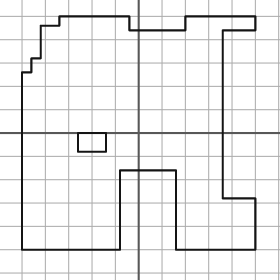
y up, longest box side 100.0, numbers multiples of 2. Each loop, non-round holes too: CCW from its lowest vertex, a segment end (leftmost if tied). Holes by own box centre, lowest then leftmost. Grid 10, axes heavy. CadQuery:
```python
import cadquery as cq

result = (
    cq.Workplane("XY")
    .moveTo(-50.0, -50.0)
    .lineTo(-8.0, -50.0)
    .lineTo(-8.0, -16.0)
    .lineTo(16.0, -16.0)
    .lineTo(16.0, -50.0)
    .lineTo(50.0, -50.0)
    .lineTo(50.0, -28.0)
    .lineTo(36.0, -28.0)
    .lineTo(36.0, 44.0)
    .lineTo(50.0, 44.0)
    .lineTo(50.0, 50.0)
    .lineTo(20.0, 50.0)
    .lineTo(20.0, 44.0)
    .lineTo(-4.0, 44.0)
    .lineTo(-4.0, 50.0)
    .lineTo(-34.0, 50.0)
    .lineTo(-34.0, 46.0)
    .lineTo(-42.0, 46.0)
    .lineTo(-42.0, 32.0)
    .lineTo(-46.0, 32.0)
    .lineTo(-46.0, 26.0)
    .lineTo(-50.0, 26.0)
    .close()
    .moveTo(-26.0, -8.0)
    .lineTo(-14.0, -8.0)
    .lineTo(-14.0, 0.0)
    .lineTo(-26.0, 0.0)
    .close()
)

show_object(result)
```